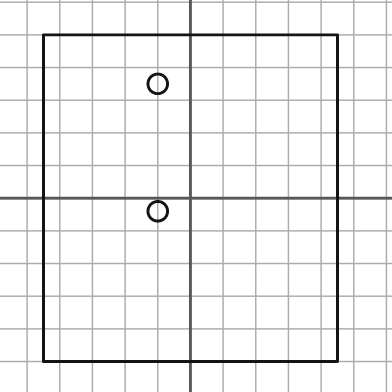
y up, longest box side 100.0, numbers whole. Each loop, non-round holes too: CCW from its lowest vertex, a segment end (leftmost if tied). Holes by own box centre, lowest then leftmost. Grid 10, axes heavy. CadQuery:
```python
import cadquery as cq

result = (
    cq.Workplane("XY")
    .moveTo(-45.0, -50.0)
    .lineTo(45.0, -50.0)
    .lineTo(45.0, 50.0)
    .lineTo(-45.0, 50.0)
    .close()
    .moveTo(-10.0, -4.0)
    .circle(3.0)
    .moveTo(-10.0, 35.0)
    .circle(3.0)
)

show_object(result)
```